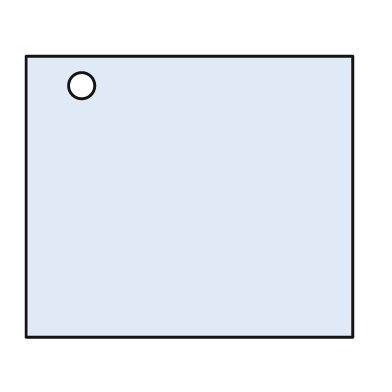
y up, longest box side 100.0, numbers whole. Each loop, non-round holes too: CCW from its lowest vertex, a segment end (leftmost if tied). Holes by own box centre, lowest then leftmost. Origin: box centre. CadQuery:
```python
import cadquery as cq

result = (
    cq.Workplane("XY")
    .moveTo(-50.0, -43.0)
    .lineTo(50.0, -43.0)
    .lineTo(50.0, 43.0)
    .lineTo(-50.0, 43.0)
    .close()
    .moveTo(-33.0, 34.0)
    .circle(4.0)
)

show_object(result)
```